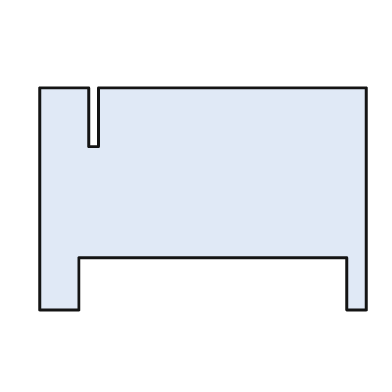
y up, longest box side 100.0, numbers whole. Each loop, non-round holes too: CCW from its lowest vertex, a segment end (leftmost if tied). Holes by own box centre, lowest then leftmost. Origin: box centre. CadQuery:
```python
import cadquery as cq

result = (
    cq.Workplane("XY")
    .moveTo(-50.0, -34.0)
    .lineTo(-38.0, -34.0)
    .lineTo(-38.0, -18.0)
    .lineTo(44.0, -18.0)
    .lineTo(44.0, -34.0)
    .lineTo(50.0, -34.0)
    .lineTo(50.0, 34.0)
    .lineTo(-32.0, 34.0)
    .lineTo(-32.0, 16.0)
    .lineTo(-35.0, 16.0)
    .lineTo(-35.0, 34.0)
    .lineTo(-50.0, 34.0)
    .close()
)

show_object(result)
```